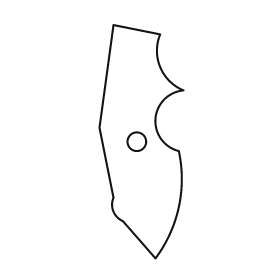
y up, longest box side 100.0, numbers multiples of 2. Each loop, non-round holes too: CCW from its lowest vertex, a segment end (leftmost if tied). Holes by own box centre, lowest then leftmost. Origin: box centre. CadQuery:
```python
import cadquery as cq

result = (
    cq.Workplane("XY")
    .moveTo(6.0, -50.0)
    .threePointArc((16.0, -28.0), (16.0, -4.0))
    .threePointArc((6.0, 10.0), (18.0, 22.0))
    .threePointArc((8.0, 32.0), (8.0, 46.0))
    .lineTo(-12.0, 50.0)
    .lineTo(-18.0, 6.0)
    .lineTo(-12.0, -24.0)
    .threePointArc((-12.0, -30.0), (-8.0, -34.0))
    .close()
    .moveTo(-2.0, 0.0)
    .circle(4.0)
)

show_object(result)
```